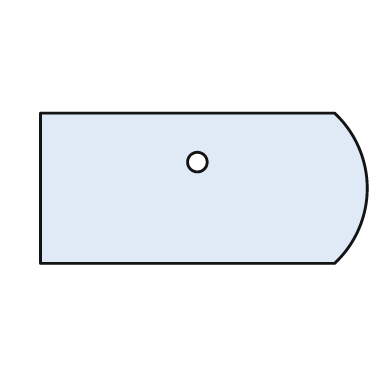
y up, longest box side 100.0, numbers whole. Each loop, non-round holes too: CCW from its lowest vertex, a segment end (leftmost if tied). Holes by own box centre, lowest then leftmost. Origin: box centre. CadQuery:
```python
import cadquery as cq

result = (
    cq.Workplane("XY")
    .moveTo(-50.0, -23.0)
    .lineTo(40.0, -23.0)
    .threePointArc((50.0, 0.0), (40.0, 23.0))
    .lineTo(-50.0, 23.0)
    .close()
    .moveTo(-2.0, 8.0)
    .circle(3.0)
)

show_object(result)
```